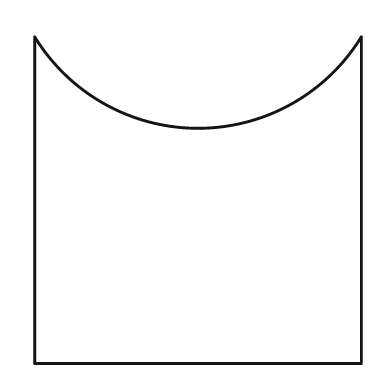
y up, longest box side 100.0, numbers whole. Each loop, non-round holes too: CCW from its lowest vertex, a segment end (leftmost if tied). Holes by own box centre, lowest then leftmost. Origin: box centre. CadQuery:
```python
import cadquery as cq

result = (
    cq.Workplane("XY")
    .moveTo(-50.0, -50.0)
    .lineTo(50.0, -50.0)
    .lineTo(50.0, 50.0)
    .threePointArc((0.0, 22.0), (-50.0, 50.0))
    .close()
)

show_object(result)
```